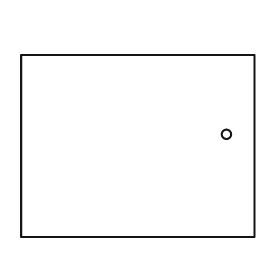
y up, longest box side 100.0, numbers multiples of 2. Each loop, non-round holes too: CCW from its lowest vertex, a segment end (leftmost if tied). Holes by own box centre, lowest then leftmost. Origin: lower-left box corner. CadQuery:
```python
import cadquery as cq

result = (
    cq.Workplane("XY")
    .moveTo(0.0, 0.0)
    .lineTo(100.0, 0.0)
    .lineTo(100.0, 78.0)
    .lineTo(0.0, 78.0)
    .close()
    .moveTo(88.0, 44.0)
    .circle(2.0)
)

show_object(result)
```